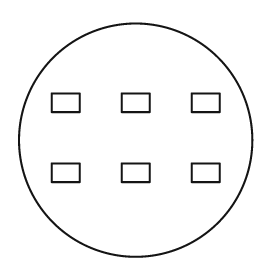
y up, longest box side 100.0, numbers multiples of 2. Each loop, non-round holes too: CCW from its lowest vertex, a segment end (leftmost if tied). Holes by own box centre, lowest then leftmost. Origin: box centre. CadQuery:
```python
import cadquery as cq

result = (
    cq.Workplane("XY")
    .moveTo(0.0, 0.0)
    .circle(50.0)
    .moveTo(-36.0, -18.0)
    .lineTo(-24.0, -18.0)
    .lineTo(-24.0, -10.0)
    .lineTo(-36.0, -10.0)
    .close()
    .moveTo(-6.0, -18.0)
    .lineTo(6.0, -18.0)
    .lineTo(6.0, -10.0)
    .lineTo(-6.0, -10.0)
    .close()
    .moveTo(24.0, -18.0)
    .lineTo(36.0, -18.0)
    .lineTo(36.0, -10.0)
    .lineTo(24.0, -10.0)
    .close()
    .moveTo(-36.0, 12.0)
    .lineTo(-24.0, 12.0)
    .lineTo(-24.0, 20.0)
    .lineTo(-36.0, 20.0)
    .close()
    .moveTo(-6.0, 12.0)
    .lineTo(6.0, 12.0)
    .lineTo(6.0, 20.0)
    .lineTo(-6.0, 20.0)
    .close()
    .moveTo(24.0, 12.0)
    .lineTo(36.0, 12.0)
    .lineTo(36.0, 20.0)
    .lineTo(24.0, 20.0)
    .close()
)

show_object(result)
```